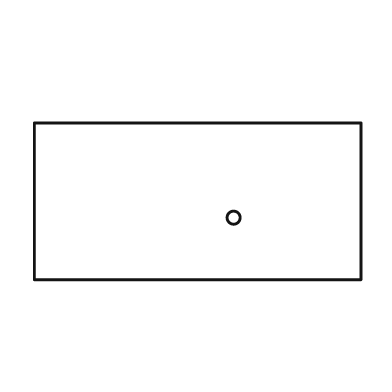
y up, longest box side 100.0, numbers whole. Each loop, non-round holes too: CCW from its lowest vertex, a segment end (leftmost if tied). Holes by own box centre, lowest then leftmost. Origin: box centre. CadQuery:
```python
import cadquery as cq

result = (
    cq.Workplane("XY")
    .moveTo(-50.0, -24.0)
    .lineTo(50.0, -24.0)
    .lineTo(50.0, 24.0)
    .lineTo(-50.0, 24.0)
    .close()
    .moveTo(11.0, -5.0)
    .circle(2.0)
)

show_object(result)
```